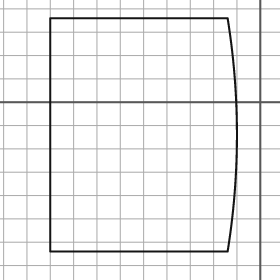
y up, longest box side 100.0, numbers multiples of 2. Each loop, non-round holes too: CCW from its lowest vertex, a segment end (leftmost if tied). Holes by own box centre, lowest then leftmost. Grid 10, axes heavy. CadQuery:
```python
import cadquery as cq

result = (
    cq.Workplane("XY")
    .moveTo(-90.0, -64.0)
    .lineTo(-14.0, -64.0)
    .threePointArc((-10.0, -14.0), (-14.0, 36.0))
    .lineTo(-90.0, 36.0)
    .close()
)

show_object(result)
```